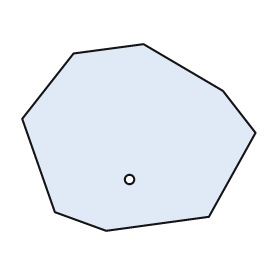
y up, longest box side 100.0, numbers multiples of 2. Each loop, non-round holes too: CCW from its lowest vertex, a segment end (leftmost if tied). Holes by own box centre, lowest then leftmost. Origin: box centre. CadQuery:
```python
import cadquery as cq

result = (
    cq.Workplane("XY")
    .moveTo(-14.0, -40.0)
    .lineTo(30.0, -34.0)
    .lineTo(50.0, 2.0)
    .lineTo(36.0, 20.0)
    .lineTo(2.0, 40.0)
    .lineTo(-28.0, 36.0)
    .lineTo(-50.0, 8.0)
    .lineTo(-36.0, -32.0)
    .close()
    .moveTo(-4.0, -18.0)
    .circle(2.0)
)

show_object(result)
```